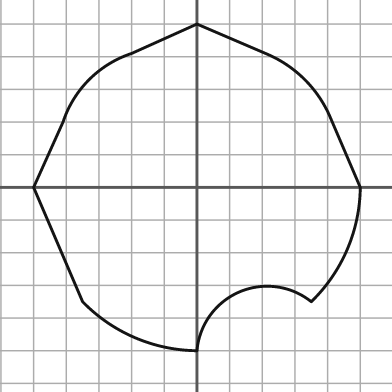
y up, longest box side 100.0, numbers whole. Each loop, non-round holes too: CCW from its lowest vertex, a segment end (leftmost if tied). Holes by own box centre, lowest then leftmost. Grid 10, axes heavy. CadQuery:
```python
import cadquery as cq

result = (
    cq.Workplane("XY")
    .moveTo(0.0, -50.0)
    .threePointArc((13.0, -32.0), (35.0, -35.0))
    .threePointArc((46.0, -19.0), (50.0, 0.0))
    .lineTo(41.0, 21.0)
    .threePointArc((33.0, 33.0), (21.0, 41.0))
    .lineTo(0.0, 50.0)
    .lineTo(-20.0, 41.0)
    .threePointArc((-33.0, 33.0), (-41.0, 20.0))
    .lineTo(-50.0, 0.0)
    .lineTo(-35.0, -35.0)
    .threePointArc((-19.0, -46.0), (0.0, -50.0))
    .close()
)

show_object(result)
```